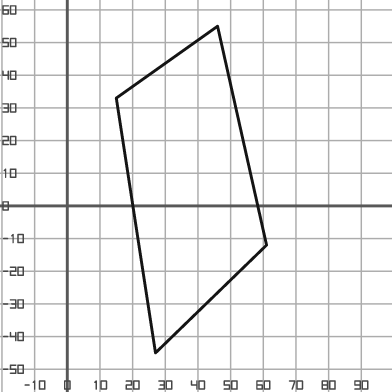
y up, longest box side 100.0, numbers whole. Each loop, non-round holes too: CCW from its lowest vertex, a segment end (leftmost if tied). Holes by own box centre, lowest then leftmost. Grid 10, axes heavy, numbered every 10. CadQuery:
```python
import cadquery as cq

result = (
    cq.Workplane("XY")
    .moveTo(27.0, -45.0)
    .lineTo(61.0, -12.0)
    .lineTo(46.0, 55.0)
    .lineTo(15.0, 33.0)
    .close()
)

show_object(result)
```